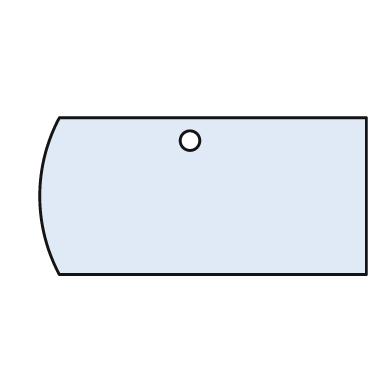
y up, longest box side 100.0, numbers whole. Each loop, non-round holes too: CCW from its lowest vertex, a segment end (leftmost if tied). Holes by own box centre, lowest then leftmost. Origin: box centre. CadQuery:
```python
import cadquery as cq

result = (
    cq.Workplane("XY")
    .moveTo(-44.0, -24.0)
    .lineTo(50.0, -24.0)
    .lineTo(50.0, 24.0)
    .lineTo(-44.0, 24.0)
    .threePointArc((-50.0, 0.0), (-44.0, -24.0))
    .close()
    .moveTo(-4.0, 17.0)
    .circle(3.0)
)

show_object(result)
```